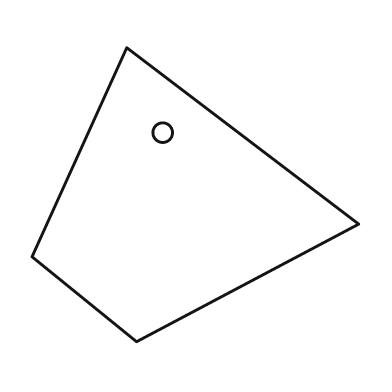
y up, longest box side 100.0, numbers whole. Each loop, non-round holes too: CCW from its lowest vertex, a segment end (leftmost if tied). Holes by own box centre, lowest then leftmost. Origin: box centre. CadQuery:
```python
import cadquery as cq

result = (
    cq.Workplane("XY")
    .moveTo(-18.0, -45.0)
    .lineTo(50.0, -9.0)
    .lineTo(-21.0, 45.0)
    .lineTo(-50.0, -19.0)
    .close()
    .moveTo(-10.0, 19.0)
    .circle(3.0)
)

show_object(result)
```